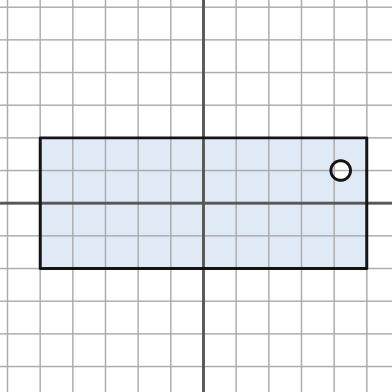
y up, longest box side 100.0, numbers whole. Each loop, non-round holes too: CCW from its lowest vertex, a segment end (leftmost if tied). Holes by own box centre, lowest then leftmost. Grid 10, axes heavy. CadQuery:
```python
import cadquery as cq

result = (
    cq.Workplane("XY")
    .moveTo(-50.0, -20.0)
    .lineTo(50.0, -20.0)
    .lineTo(50.0, 20.0)
    .lineTo(-50.0, 20.0)
    .close()
    .moveTo(42.0, 10.0)
    .circle(3.0)
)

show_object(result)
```